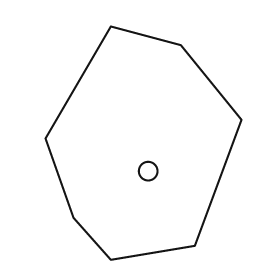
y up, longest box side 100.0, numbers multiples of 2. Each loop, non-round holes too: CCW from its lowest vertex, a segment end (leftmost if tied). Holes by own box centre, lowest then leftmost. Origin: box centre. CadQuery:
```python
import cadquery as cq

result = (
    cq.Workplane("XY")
    .moveTo(-14.0, -50.0)
    .lineTo(22.0, -44.0)
    .lineTo(42.0, 10.0)
    .lineTo(16.0, 42.0)
    .lineTo(-14.0, 50.0)
    .lineTo(-42.0, 2.0)
    .lineTo(-30.0, -32.0)
    .close()
    .moveTo(2.0, -12.0)
    .circle(4.0)
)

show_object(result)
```